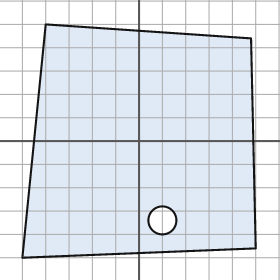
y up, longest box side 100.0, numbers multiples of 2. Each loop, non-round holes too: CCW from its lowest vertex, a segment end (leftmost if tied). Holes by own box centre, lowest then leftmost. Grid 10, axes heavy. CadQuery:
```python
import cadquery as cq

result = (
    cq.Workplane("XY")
    .moveTo(-50.0, -50.0)
    .lineTo(50.0, -46.0)
    .lineTo(48.0, 44.0)
    .lineTo(-40.0, 50.0)
    .close()
    .moveTo(10.0, -34.0)
    .circle(6.0)
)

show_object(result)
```